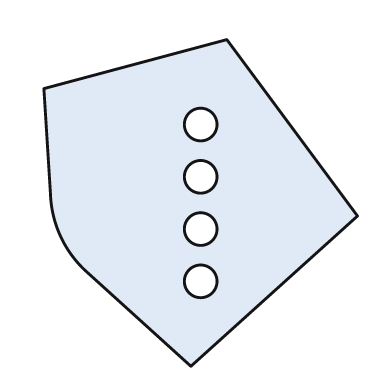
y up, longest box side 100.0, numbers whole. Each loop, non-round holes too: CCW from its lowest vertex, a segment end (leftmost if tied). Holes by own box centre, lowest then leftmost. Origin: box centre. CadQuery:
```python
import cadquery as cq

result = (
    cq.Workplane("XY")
    .moveTo(-3.0, -50.0)
    .lineTo(48.0, -4.0)
    .lineTo(8.0, 50.0)
    .lineTo(-48.0, 35.0)
    .lineTo(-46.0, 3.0)
    .threePointArc((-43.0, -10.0), (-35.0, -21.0))
    .close()
    .moveTo(0.0, -24.0)
    .circle(5.0)
    .moveTo(0.0, -8.0)
    .circle(5.0)
    .moveTo(0.0, 8.0)
    .circle(5.0)
    .moveTo(0.0, 24.0)
    .circle(5.0)
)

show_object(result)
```